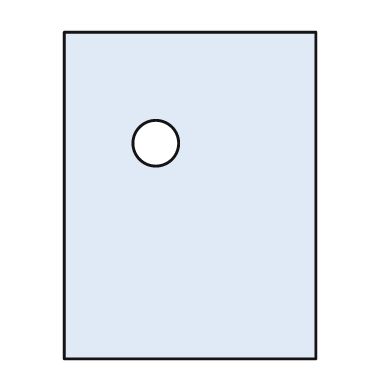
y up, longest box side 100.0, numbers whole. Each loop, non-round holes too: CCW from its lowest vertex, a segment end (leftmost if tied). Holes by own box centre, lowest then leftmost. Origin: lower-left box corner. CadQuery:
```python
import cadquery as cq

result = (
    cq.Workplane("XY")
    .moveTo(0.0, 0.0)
    .lineTo(77.0, 0.0)
    .lineTo(77.0, 100.0)
    .lineTo(0.0, 100.0)
    .close()
    .moveTo(28.0, 66.0)
    .circle(7.0)
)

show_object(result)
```